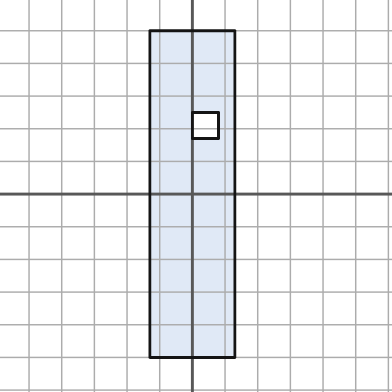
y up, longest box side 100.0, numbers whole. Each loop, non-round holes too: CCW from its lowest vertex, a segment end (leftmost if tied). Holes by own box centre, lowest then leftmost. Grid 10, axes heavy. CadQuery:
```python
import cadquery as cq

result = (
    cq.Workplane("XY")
    .moveTo(-13.0, -50.0)
    .lineTo(13.0, -50.0)
    .lineTo(13.0, 50.0)
    .lineTo(-13.0, 50.0)
    .close()
    .moveTo(0.0, 17.0)
    .lineTo(8.0, 17.0)
    .lineTo(8.0, 25.0)
    .lineTo(0.0, 25.0)
    .close()
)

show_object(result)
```